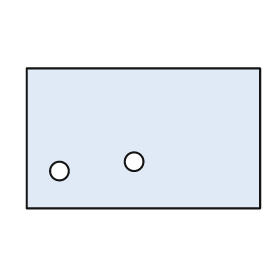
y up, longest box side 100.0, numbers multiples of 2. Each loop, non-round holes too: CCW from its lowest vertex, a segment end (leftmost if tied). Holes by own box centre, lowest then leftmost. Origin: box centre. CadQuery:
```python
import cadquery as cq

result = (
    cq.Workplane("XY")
    .moveTo(-50.0, -30.0)
    .lineTo(50.0, -30.0)
    .lineTo(50.0, 30.0)
    .lineTo(-50.0, 30.0)
    .close()
    .moveTo(-36.0, -14.0)
    .circle(4.0)
    .moveTo(-4.0, -10.0)
    .circle(4.0)
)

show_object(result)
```